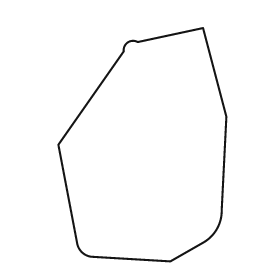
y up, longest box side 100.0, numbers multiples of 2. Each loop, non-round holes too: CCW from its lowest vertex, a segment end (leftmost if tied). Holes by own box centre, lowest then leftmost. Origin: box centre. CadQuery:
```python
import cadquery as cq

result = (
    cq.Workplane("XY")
    .moveTo(12.0, -50.0)
    .lineTo(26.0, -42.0)
    .threePointArc((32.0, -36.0), (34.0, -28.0))
    .lineTo(36.0, 12.0)
    .lineTo(26.0, 50.0)
    .lineTo(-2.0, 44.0)
    .threePointArc((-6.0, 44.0), (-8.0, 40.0))
    .lineTo(-36.0, 0.0)
    .lineTo(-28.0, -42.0)
    .threePointArc((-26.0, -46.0), (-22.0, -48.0))
    .close()
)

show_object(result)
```